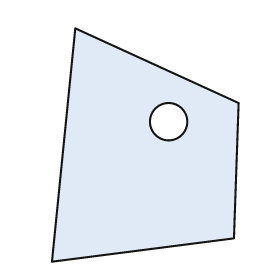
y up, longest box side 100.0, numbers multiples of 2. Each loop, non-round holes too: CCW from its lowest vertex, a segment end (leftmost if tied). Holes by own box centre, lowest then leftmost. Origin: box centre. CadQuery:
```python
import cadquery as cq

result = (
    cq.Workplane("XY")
    .moveTo(-40.0, -50.0)
    .lineTo(38.0, -40.0)
    .lineTo(40.0, 18.0)
    .lineTo(-30.0, 50.0)
    .close()
    .moveTo(10.0, 10.0)
    .circle(8.0)
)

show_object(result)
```